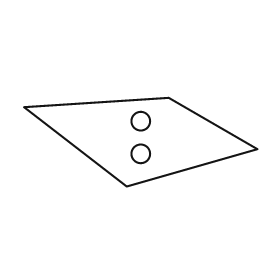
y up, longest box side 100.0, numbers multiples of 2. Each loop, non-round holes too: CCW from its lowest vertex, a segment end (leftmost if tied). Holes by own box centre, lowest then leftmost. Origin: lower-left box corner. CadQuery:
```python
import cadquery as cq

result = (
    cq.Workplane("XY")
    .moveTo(44.0, 0.0)
    .lineTo(100.0, 16.0)
    .lineTo(62.0, 38.0)
    .lineTo(0.0, 34.0)
    .close()
    .moveTo(50.0, 14.0)
    .circle(4.0)
    .moveTo(50.0, 28.0)
    .circle(4.0)
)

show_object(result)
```